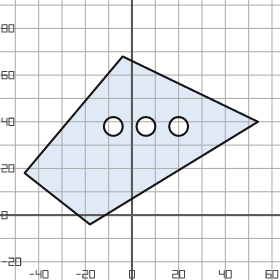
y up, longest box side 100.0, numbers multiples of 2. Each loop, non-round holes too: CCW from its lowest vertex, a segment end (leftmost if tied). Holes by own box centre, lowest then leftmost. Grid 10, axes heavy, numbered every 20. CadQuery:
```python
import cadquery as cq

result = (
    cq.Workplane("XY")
    .moveTo(-18.0, -4.0)
    .lineTo(54.0, 40.0)
    .lineTo(-4.0, 68.0)
    .lineTo(-46.0, 18.0)
    .close()
    .moveTo(-8.0, 38.0)
    .circle(4.0)
    .moveTo(6.0, 38.0)
    .circle(4.0)
    .moveTo(20.0, 38.0)
    .circle(4.0)
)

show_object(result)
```